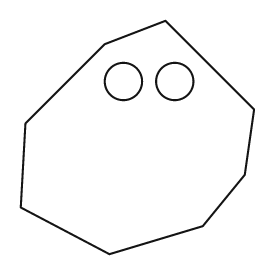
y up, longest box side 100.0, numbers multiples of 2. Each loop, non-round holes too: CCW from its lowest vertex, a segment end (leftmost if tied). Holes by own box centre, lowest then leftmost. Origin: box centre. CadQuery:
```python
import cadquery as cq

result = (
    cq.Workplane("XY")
    .moveTo(-12.0, -50.0)
    .lineTo(28.0, -38.0)
    .lineTo(46.0, -16.0)
    .lineTo(50.0, 12.0)
    .lineTo(12.0, 50.0)
    .lineTo(-14.0, 40.0)
    .lineTo(-48.0, 6.0)
    .lineTo(-50.0, -30.0)
    .close()
    .moveTo(-6.0, 24.0)
    .circle(8.0)
    .moveTo(16.0, 24.0)
    .circle(8.0)
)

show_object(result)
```